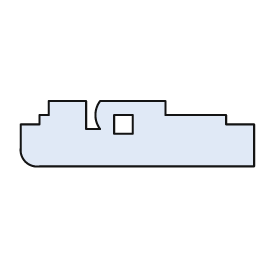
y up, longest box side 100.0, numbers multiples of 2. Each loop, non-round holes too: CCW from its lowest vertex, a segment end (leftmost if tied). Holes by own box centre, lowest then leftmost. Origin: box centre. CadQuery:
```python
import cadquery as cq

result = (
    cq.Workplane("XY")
    .moveTo(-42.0, -14.0)
    .lineTo(50.0, -14.0)
    .lineTo(50.0, 4.0)
    .lineTo(38.0, 4.0)
    .lineTo(38.0, 8.0)
    .lineTo(12.0, 8.0)
    .lineTo(12.0, 14.0)
    .lineTo(-16.0, 14.0)
    .threePointArc((-18.0, 8.0), (-16.0, 2.0))
    .lineTo(-22.0, 2.0)
    .lineTo(-22.0, 14.0)
    .lineTo(-38.0, 14.0)
    .lineTo(-38.0, 8.0)
    .lineTo(-42.0, 8.0)
    .lineTo(-42.0, 4.0)
    .lineTo(-50.0, 4.0)
    .lineTo(-50.0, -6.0)
    .threePointArc((-48.0, -12.0), (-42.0, -14.0))
    .close()
    .moveTo(-10.0, 0.0)
    .lineTo(-2.0, 0.0)
    .lineTo(-2.0, 8.0)
    .lineTo(-10.0, 8.0)
    .close()
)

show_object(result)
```